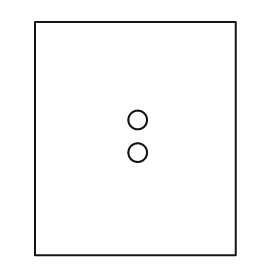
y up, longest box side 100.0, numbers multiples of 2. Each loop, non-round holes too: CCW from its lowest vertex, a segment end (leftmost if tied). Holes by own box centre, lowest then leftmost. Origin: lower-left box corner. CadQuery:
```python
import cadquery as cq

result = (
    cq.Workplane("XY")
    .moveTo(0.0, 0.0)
    .lineTo(86.0, 0.0)
    .lineTo(86.0, 100.0)
    .lineTo(0.0, 100.0)
    .close()
    .moveTo(44.0, 44.0)
    .circle(4.0)
    .moveTo(44.0, 58.0)
    .circle(4.0)
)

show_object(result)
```